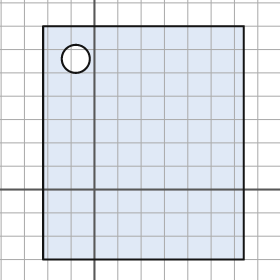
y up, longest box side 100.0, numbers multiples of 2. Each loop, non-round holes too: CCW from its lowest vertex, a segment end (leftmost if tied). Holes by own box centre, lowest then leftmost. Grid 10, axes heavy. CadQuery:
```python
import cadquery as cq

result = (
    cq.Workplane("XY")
    .moveTo(-22.0, -30.0)
    .lineTo(64.0, -30.0)
    .lineTo(64.0, 70.0)
    .lineTo(-22.0, 70.0)
    .close()
    .moveTo(-8.0, 56.0)
    .circle(6.0)
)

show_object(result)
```